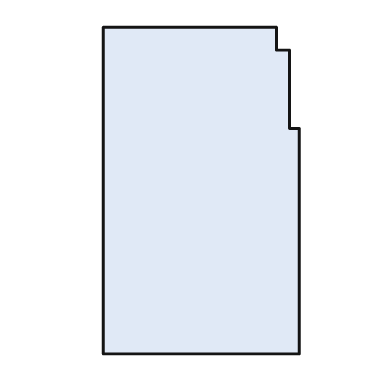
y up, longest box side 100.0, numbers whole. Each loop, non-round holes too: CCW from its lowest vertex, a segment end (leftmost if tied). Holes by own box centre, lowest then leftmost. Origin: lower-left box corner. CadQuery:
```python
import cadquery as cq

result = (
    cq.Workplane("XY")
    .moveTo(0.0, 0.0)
    .lineTo(60.0, 0.0)
    .lineTo(60.0, 69.0)
    .lineTo(57.0, 69.0)
    .lineTo(57.0, 93.0)
    .lineTo(53.0, 93.0)
    .lineTo(53.0, 100.0)
    .lineTo(0.0, 100.0)
    .close()
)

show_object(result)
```